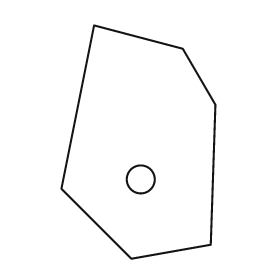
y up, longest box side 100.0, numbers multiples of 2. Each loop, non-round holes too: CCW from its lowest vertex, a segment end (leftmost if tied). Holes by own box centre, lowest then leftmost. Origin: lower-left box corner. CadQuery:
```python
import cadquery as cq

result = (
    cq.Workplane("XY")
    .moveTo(30.0, 0.0)
    .lineTo(64.0, 6.0)
    .lineTo(66.0, 66.0)
    .lineTo(52.0, 90.0)
    .lineTo(14.0, 100.0)
    .lineTo(0.0, 30.0)
    .close()
    .moveTo(34.0, 34.0)
    .circle(6.0)
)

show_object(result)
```